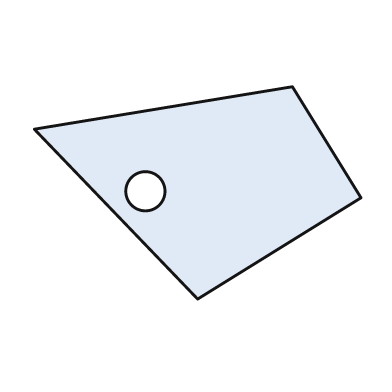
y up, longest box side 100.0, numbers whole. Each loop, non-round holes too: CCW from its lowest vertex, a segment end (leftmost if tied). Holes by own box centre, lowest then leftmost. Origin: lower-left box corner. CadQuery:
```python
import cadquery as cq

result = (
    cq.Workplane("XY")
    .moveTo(50.0, 0.0)
    .lineTo(100.0, 31.0)
    .lineTo(79.0, 65.0)
    .lineTo(0.0, 52.0)
    .close()
    .moveTo(34.0, 33.0)
    .circle(6.0)
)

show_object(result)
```